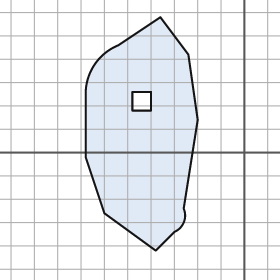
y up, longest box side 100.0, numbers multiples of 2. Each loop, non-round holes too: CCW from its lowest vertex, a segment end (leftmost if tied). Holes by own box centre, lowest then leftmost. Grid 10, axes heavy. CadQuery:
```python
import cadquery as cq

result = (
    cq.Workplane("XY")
    .moveTo(-38.0, -42.0)
    .lineTo(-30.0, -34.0)
    .threePointArc((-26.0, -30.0), (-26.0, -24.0))
    .lineTo(-20.0, 14.0)
    .lineTo(-24.0, 42.0)
    .lineTo(-36.0, 58.0)
    .lineTo(-54.0, 46.0)
    .threePointArc((-64.0, 38.0), (-68.0, 26.0))
    .lineTo(-68.0, -2.0)
    .lineTo(-60.0, -26.0)
    .close()
    .moveTo(-48.0, 18.0)
    .lineTo(-40.0, 18.0)
    .lineTo(-40.0, 26.0)
    .lineTo(-48.0, 26.0)
    .close()
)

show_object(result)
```